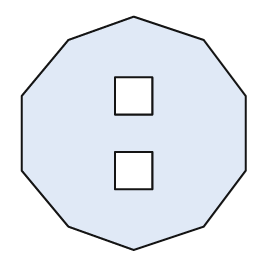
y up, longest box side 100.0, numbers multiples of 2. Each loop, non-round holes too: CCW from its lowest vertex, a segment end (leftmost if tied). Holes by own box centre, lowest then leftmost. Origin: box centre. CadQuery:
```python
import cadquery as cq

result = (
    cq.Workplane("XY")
    .moveTo(0.0, -50.0)
    .lineTo(30.0, -40.0)
    .lineTo(48.0, -16.0)
    .lineTo(48.0, 16.0)
    .lineTo(30.0, 40.0)
    .lineTo(0.0, 50.0)
    .lineTo(-28.0, 40.0)
    .lineTo(-48.0, 16.0)
    .lineTo(-48.0, -16.0)
    .lineTo(-28.0, -40.0)
    .close()
    .moveTo(-8.0, -24.0)
    .lineTo(8.0, -24.0)
    .lineTo(8.0, -8.0)
    .lineTo(-8.0, -8.0)
    .close()
    .moveTo(-8.0, 8.0)
    .lineTo(8.0, 8.0)
    .lineTo(8.0, 24.0)
    .lineTo(-8.0, 24.0)
    .close()
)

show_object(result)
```